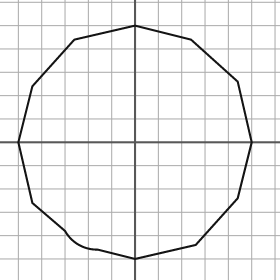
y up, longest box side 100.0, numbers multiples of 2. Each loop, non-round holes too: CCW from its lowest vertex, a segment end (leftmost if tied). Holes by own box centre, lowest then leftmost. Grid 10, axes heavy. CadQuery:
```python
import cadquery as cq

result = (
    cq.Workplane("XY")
    .moveTo(0.0, -50.0)
    .lineTo(26.0, -44.0)
    .lineTo(44.0, -24.0)
    .lineTo(50.0, 0.0)
    .lineTo(44.0, 26.0)
    .lineTo(24.0, 44.0)
    .lineTo(0.0, 50.0)
    .lineTo(-26.0, 44.0)
    .lineTo(-44.0, 24.0)
    .lineTo(-50.0, 0.0)
    .lineTo(-44.0, -26.0)
    .lineTo(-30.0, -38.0)
    .threePointArc((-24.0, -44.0), (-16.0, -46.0))
    .close()
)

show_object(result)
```